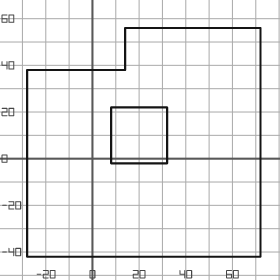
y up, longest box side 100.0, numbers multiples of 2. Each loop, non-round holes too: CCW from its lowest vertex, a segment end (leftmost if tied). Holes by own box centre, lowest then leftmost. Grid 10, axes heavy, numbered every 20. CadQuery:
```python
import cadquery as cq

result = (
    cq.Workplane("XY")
    .moveTo(-28.0, -42.0)
    .lineTo(72.0, -42.0)
    .lineTo(72.0, 56.0)
    .lineTo(14.0, 56.0)
    .lineTo(14.0, 38.0)
    .lineTo(-28.0, 38.0)
    .close()
    .moveTo(8.0, -2.0)
    .lineTo(32.0, -2.0)
    .lineTo(32.0, 22.0)
    .lineTo(8.0, 22.0)
    .close()
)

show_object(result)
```